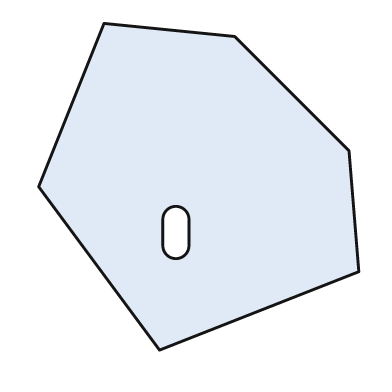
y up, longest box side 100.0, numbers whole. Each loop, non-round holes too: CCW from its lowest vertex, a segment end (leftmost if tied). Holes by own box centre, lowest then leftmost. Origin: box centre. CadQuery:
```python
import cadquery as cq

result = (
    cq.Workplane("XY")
    .moveTo(-12.0, -50.0)
    .lineTo(49.0, -26.0)
    .lineTo(46.0, 11.0)
    .lineTo(11.0, 46.0)
    .lineTo(-29.0, 50.0)
    .lineTo(-49.0, 0.0)
    .close()
    .moveTo(-11.0, -18.0)
    .threePointArc((-7.0, -22.0), (-3.0, -18.0))
    .lineTo(-3.0, -10.0)
    .threePointArc((-7.0, -6.0), (-11.0, -10.0))
    .close()
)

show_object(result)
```